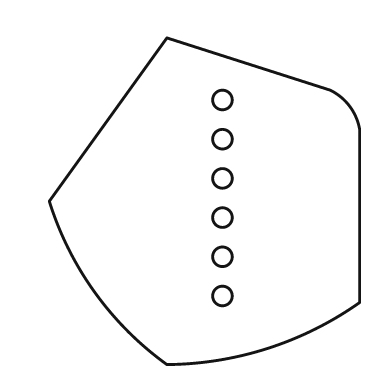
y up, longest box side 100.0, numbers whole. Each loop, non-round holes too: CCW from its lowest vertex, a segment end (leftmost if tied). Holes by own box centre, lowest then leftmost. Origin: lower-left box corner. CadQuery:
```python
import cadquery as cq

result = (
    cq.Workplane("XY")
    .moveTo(36.0, 0.0)
    .threePointArc((67.0, 5.0), (95.0, 19.0))
    .lineTo(95.0, 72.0)
    .threePointArc((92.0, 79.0), (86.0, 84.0))
    .lineTo(36.0, 100.0)
    .lineTo(0.0, 50.0)
    .threePointArc((14.0, 22.0), (36.0, 0.0))
    .close()
    .moveTo(53.0, 21.0)
    .circle(3.0)
    .moveTo(53.0, 33.0)
    .circle(3.0)
    .moveTo(53.0, 45.0)
    .circle(3.0)
    .moveTo(53.0, 57.0)
    .circle(3.0)
    .moveTo(53.0, 69.0)
    .circle(3.0)
    .moveTo(53.0, 81.0)
    .circle(3.0)
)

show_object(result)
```